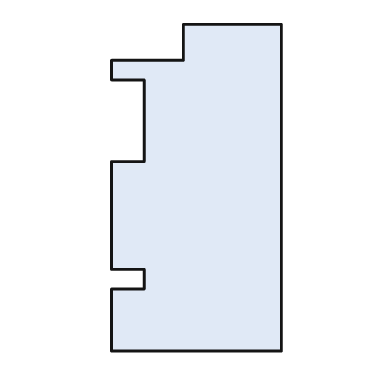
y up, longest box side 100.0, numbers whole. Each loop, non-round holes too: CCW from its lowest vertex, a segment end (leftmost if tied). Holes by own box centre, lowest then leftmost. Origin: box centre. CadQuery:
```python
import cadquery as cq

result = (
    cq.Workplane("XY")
    .moveTo(-26.0, -50.0)
    .lineTo(26.0, -50.0)
    .lineTo(26.0, 50.0)
    .lineTo(-4.0, 50.0)
    .lineTo(-4.0, 39.0)
    .lineTo(-26.0, 39.0)
    .lineTo(-26.0, 33.0)
    .lineTo(-16.0, 33.0)
    .lineTo(-16.0, 8.0)
    .lineTo(-26.0, 8.0)
    .lineTo(-26.0, -25.0)
    .lineTo(-16.0, -25.0)
    .lineTo(-16.0, -31.0)
    .lineTo(-26.0, -31.0)
    .close()
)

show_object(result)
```